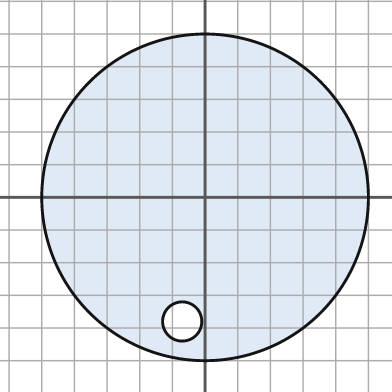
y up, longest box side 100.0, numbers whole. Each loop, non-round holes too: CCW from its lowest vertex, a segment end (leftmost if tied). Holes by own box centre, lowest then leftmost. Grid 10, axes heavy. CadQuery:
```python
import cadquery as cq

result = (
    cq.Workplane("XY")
    .moveTo(0.0, 0.0)
    .circle(50.0)
    .moveTo(-7.0, -38.0)
    .circle(6.0)
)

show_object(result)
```